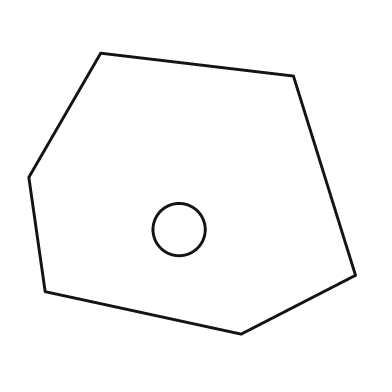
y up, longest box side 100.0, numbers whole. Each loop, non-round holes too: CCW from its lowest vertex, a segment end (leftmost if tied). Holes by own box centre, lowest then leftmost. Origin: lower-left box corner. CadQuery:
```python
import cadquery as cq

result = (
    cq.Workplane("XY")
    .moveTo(65.0, 0.0)
    .lineTo(100.0, 18.0)
    .lineTo(81.0, 79.0)
    .lineTo(22.0, 86.0)
    .lineTo(0.0, 48.0)
    .lineTo(5.0, 13.0)
    .close()
    .moveTo(46.0, 32.0)
    .circle(8.0)
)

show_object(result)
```